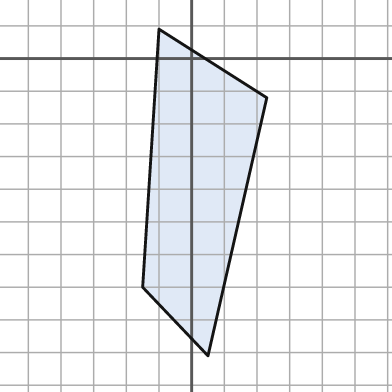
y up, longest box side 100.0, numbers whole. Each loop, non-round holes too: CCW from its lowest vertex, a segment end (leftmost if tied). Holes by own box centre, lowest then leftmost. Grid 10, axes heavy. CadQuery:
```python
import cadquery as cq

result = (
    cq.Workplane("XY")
    .moveTo(5.0, -91.0)
    .lineTo(23.0, -12.0)
    .lineTo(-10.0, 9.0)
    .lineTo(-15.0, -70.0)
    .close()
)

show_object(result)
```